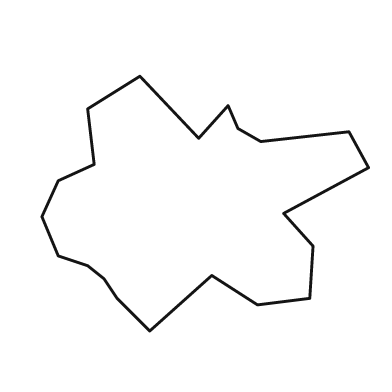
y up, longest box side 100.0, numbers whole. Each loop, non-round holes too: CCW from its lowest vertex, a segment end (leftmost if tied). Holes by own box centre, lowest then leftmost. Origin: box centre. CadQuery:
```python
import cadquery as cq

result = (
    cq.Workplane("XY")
    .moveTo(-17.0, -39.0)
    .lineTo(2.0, -22.0)
    .lineTo(16.0, -31.0)
    .lineTo(32.0, -29.0)
    .lineTo(33.0, -13.0)
    .lineTo(24.0, -3.0)
    .lineTo(50.0, 11.0)
    .lineTo(44.0, 22.0)
    .lineTo(17.0, 19.0)
    .lineTo(10.0, 23.0)
    .lineTo(7.0, 30.0)
    .lineTo(-2.0, 20.0)
    .lineTo(-20.0, 39.0)
    .lineTo(-36.0, 29.0)
    .lineTo(-34.0, 12.0)
    .lineTo(-45.0, 7.0)
    .lineTo(-50.0, -4.0)
    .lineTo(-45.0, -16.0)
    .lineTo(-36.0, -19.0)
    .lineTo(-31.0, -23.0)
    .lineTo(-27.0, -29.0)
    .close()
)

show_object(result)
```